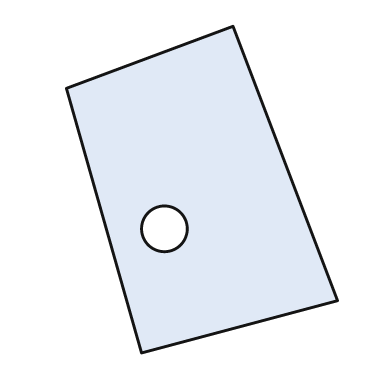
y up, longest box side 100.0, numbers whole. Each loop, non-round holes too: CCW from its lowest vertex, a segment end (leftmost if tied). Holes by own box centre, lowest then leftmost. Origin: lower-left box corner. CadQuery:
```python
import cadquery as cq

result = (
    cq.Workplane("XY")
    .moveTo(23.0, 0.0)
    .lineTo(83.0, 16.0)
    .lineTo(51.0, 100.0)
    .lineTo(0.0, 81.0)
    .close()
    .moveTo(30.0, 38.0)
    .circle(7.0)
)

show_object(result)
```